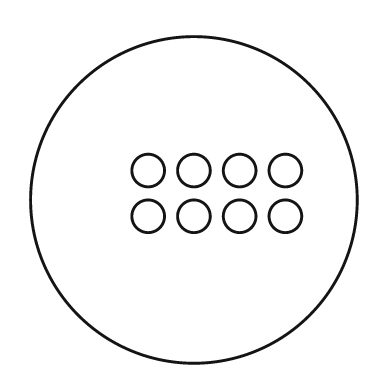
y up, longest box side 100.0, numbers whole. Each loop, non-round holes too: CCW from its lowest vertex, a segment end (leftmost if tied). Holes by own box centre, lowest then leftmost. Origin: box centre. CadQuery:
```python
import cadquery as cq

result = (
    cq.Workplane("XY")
    .moveTo(0.0, 0.0)
    .circle(50.0)
    .moveTo(-14.0, -5.0)
    .circle(5.0)
    .moveTo(0.0, -5.0)
    .circle(5.0)
    .moveTo(14.0, -5.0)
    .circle(5.0)
    .moveTo(28.0, -5.0)
    .circle(5.0)
    .moveTo(-14.0, 9.0)
    .circle(5.0)
    .moveTo(0.0, 9.0)
    .circle(5.0)
    .moveTo(14.0, 9.0)
    .circle(5.0)
    .moveTo(28.0, 9.0)
    .circle(5.0)
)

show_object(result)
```